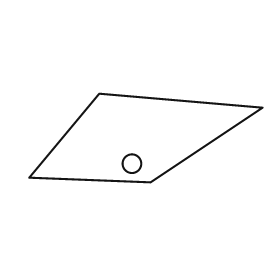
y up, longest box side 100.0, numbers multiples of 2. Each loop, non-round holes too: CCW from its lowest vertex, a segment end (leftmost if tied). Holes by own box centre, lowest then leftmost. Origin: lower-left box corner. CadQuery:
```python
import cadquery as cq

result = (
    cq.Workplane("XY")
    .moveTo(52.0, 0.0)
    .lineTo(100.0, 32.0)
    .lineTo(30.0, 38.0)
    .lineTo(0.0, 2.0)
    .close()
    .moveTo(44.0, 8.0)
    .circle(4.0)
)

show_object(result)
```